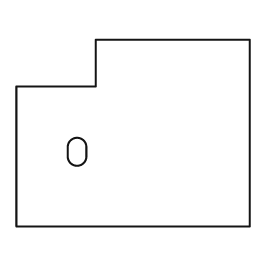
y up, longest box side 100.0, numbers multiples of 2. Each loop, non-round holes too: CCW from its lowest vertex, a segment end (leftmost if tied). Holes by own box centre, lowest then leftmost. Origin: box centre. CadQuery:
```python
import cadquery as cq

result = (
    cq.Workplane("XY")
    .moveTo(-50.0, -40.0)
    .lineTo(50.0, -40.0)
    .lineTo(50.0, 40.0)
    .lineTo(-16.0, 40.0)
    .lineTo(-16.0, 20.0)
    .lineTo(-50.0, 20.0)
    .close()
    .moveTo(-28.0, -10.0)
    .threePointArc((-24.0, -14.0), (-20.0, -10.0))
    .lineTo(-20.0, -6.0)
    .threePointArc((-24.0, -2.0), (-28.0, -6.0))
    .close()
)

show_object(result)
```